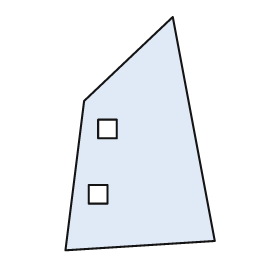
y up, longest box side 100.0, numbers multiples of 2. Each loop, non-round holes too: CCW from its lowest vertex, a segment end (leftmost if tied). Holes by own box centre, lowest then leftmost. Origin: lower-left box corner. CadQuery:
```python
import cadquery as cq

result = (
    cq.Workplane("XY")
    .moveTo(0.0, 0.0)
    .lineTo(64.0, 4.0)
    .lineTo(46.0, 100.0)
    .lineTo(8.0, 64.0)
    .close()
    .moveTo(10.0, 20.0)
    .lineTo(18.0, 20.0)
    .lineTo(18.0, 28.0)
    .lineTo(10.0, 28.0)
    .close()
    .moveTo(14.0, 48.0)
    .lineTo(22.0, 48.0)
    .lineTo(22.0, 56.0)
    .lineTo(14.0, 56.0)
    .close()
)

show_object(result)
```